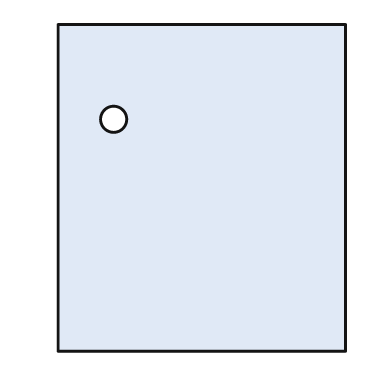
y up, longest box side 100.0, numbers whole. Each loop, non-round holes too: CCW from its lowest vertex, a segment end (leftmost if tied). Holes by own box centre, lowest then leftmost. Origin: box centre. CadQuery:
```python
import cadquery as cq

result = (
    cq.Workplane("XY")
    .moveTo(-44.0, -50.0)
    .lineTo(44.0, -50.0)
    .lineTo(44.0, 50.0)
    .lineTo(-44.0, 50.0)
    .close()
    .moveTo(-27.0, 21.0)
    .circle(4.0)
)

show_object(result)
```